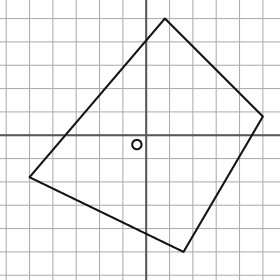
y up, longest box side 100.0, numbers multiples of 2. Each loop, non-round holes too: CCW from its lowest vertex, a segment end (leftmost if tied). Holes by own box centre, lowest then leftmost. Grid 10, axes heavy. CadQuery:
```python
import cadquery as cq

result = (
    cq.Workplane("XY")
    .moveTo(16.0, -50.0)
    .lineTo(50.0, 8.0)
    .lineTo(8.0, 50.0)
    .lineTo(-50.0, -18.0)
    .close()
    .moveTo(-4.0, -4.0)
    .circle(2.0)
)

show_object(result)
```